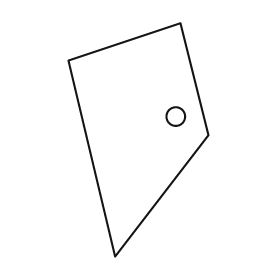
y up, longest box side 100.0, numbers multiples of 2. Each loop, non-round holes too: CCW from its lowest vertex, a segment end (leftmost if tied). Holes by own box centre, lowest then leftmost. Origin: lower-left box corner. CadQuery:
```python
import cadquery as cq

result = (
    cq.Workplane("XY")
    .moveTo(20.0, 0.0)
    .lineTo(60.0, 52.0)
    .lineTo(48.0, 100.0)
    .lineTo(0.0, 84.0)
    .close()
    .moveTo(46.0, 60.0)
    .circle(4.0)
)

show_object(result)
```